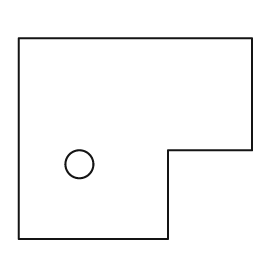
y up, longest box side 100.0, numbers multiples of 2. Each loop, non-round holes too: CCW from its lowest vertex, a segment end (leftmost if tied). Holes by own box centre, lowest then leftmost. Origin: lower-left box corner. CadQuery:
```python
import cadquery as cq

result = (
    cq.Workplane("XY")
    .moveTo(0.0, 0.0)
    .lineTo(64.0, 0.0)
    .lineTo(64.0, 38.0)
    .lineTo(100.0, 38.0)
    .lineTo(100.0, 86.0)
    .lineTo(0.0, 86.0)
    .close()
    .moveTo(26.0, 32.0)
    .circle(6.0)
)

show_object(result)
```